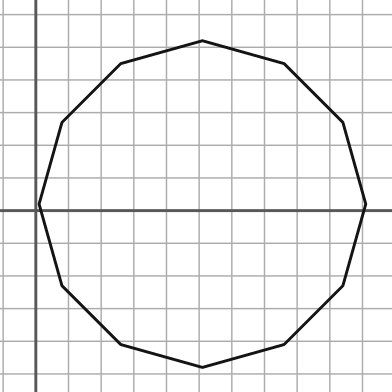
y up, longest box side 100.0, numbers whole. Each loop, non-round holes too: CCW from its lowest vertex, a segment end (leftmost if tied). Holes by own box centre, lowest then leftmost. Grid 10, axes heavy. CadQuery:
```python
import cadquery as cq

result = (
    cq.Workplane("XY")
    .moveTo(51.0, -48.0)
    .lineTo(76.0, -41.0)
    .lineTo(94.0, -23.0)
    .lineTo(101.0, 2.0)
    .lineTo(94.0, 27.0)
    .lineTo(76.0, 45.0)
    .lineTo(51.0, 52.0)
    .lineTo(26.0, 45.0)
    .lineTo(8.0, 27.0)
    .lineTo(1.0, 2.0)
    .lineTo(8.0, -23.0)
    .lineTo(26.0, -41.0)
    .close()
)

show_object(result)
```